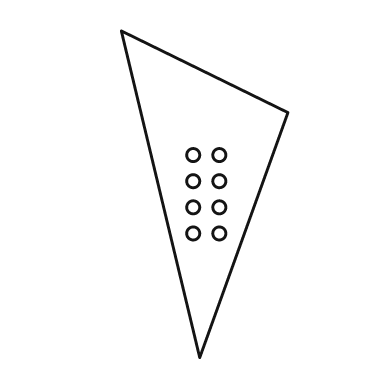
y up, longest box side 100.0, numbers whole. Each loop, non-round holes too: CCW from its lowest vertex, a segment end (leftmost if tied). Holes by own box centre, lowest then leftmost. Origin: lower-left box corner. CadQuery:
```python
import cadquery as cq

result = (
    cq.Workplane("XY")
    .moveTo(24.0, 0.0)
    .lineTo(51.0, 75.0)
    .lineTo(0.0, 100.0)
    .close()
    .moveTo(22.0, 38.0)
    .circle(2.0)
    .moveTo(30.0, 38.0)
    .circle(2.0)
    .moveTo(22.0, 46.0)
    .circle(2.0)
    .moveTo(30.0, 46.0)
    .circle(2.0)
    .moveTo(22.0, 54.0)
    .circle(2.0)
    .moveTo(30.0, 54.0)
    .circle(2.0)
    .moveTo(22.0, 62.0)
    .circle(2.0)
    .moveTo(30.0, 62.0)
    .circle(2.0)
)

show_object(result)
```